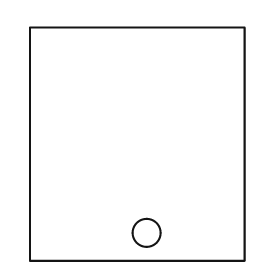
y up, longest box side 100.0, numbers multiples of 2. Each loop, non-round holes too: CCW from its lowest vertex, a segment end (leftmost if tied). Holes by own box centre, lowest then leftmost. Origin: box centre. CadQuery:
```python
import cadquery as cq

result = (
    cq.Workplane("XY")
    .moveTo(-46.0, -50.0)
    .lineTo(46.0, -50.0)
    .lineTo(46.0, 50.0)
    .lineTo(-46.0, 50.0)
    .close()
    .moveTo(4.0, -38.0)
    .circle(6.0)
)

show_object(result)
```